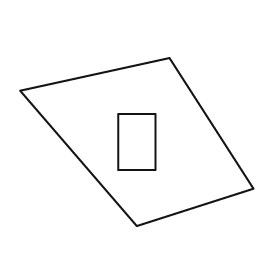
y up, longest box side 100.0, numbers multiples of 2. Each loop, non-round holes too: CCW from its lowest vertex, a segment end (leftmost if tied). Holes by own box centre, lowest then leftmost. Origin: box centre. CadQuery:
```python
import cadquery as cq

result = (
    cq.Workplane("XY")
    .moveTo(0.0, -36.0)
    .lineTo(50.0, -20.0)
    .lineTo(14.0, 36.0)
    .lineTo(-50.0, 22.0)
    .close()
    .moveTo(-8.0, -12.0)
    .lineTo(8.0, -12.0)
    .lineTo(8.0, 12.0)
    .lineTo(-8.0, 12.0)
    .close()
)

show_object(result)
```